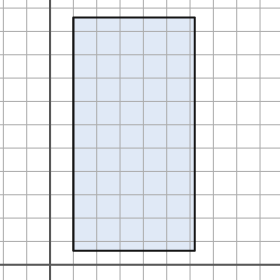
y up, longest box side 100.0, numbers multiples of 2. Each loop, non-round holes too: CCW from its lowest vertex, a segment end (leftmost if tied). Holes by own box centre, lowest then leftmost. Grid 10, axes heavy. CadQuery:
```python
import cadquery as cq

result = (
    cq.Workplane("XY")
    .moveTo(10.0, 6.0)
    .lineTo(62.0, 6.0)
    .lineTo(62.0, 106.0)
    .lineTo(10.0, 106.0)
    .close()
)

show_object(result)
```